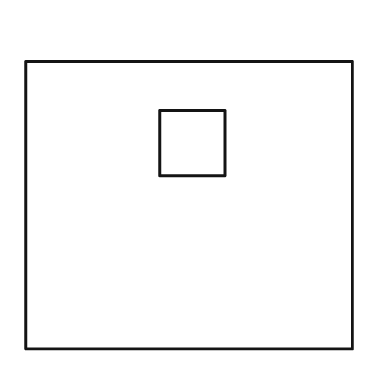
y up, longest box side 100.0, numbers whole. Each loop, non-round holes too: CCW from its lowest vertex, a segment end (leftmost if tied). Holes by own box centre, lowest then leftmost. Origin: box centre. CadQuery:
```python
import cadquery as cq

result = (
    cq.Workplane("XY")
    .moveTo(-50.0, -44.0)
    .lineTo(50.0, -44.0)
    .lineTo(50.0, 44.0)
    .lineTo(-50.0, 44.0)
    .close()
    .moveTo(-9.0, 9.0)
    .lineTo(11.0, 9.0)
    .lineTo(11.0, 29.0)
    .lineTo(-9.0, 29.0)
    .close()
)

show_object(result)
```